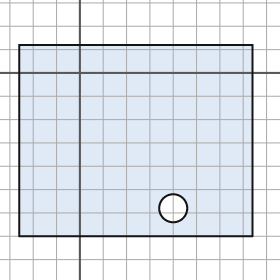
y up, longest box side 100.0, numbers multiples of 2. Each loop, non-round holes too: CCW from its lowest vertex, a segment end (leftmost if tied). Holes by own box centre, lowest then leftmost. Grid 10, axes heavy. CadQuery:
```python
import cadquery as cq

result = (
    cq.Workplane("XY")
    .moveTo(-26.0, -70.0)
    .lineTo(74.0, -70.0)
    .lineTo(74.0, 12.0)
    .lineTo(-26.0, 12.0)
    .close()
    .moveTo(40.0, -58.0)
    .circle(6.0)
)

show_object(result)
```